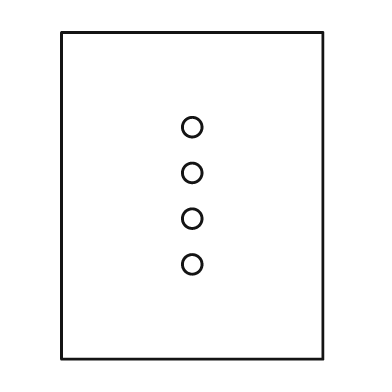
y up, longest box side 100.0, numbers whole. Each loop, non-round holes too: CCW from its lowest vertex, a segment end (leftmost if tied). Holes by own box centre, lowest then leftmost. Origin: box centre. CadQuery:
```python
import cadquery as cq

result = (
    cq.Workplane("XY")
    .moveTo(-40.0, -50.0)
    .lineTo(40.0, -50.0)
    .lineTo(40.0, 50.0)
    .lineTo(-40.0, 50.0)
    .close()
    .moveTo(0.0, -21.0)
    .circle(3.0)
    .moveTo(0.0, -7.0)
    .circle(3.0)
    .moveTo(0.0, 7.0)
    .circle(3.0)
    .moveTo(0.0, 21.0)
    .circle(3.0)
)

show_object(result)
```